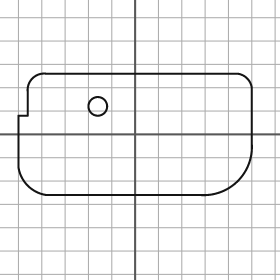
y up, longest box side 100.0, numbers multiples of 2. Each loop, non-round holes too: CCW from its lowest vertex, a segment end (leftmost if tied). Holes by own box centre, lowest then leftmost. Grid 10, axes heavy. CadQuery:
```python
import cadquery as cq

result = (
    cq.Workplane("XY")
    .moveTo(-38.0, -26.0)
    .lineTo(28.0, -26.0)
    .threePointArc((44.0, -20.0), (50.0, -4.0))
    .lineTo(50.0, 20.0)
    .threePointArc((48.0, 24.0), (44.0, 26.0))
    .lineTo(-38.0, 26.0)
    .threePointArc((-44.0, 24.0), (-46.0, 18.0))
    .lineTo(-46.0, 8.0)
    .lineTo(-50.0, 8.0)
    .lineTo(-50.0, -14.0)
    .threePointArc((-46.0, -22.0), (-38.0, -26.0))
    .close()
    .moveTo(-16.0, 12.0)
    .circle(4.0)
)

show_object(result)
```